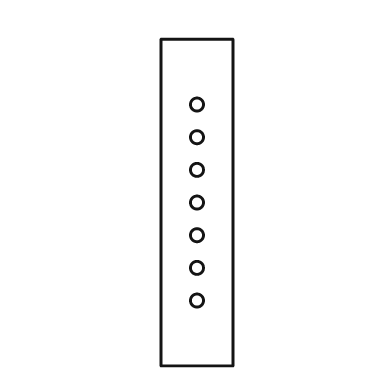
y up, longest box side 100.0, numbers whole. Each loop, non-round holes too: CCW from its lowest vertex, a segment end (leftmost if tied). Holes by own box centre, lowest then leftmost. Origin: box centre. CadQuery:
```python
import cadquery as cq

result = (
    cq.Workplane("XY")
    .moveTo(-11.0, -50.0)
    .lineTo(11.0, -50.0)
    .lineTo(11.0, 50.0)
    .lineTo(-11.0, 50.0)
    .close()
    .moveTo(0.0, -30.0)
    .circle(2.0)
    .moveTo(0.0, -20.0)
    .circle(2.0)
    .moveTo(0.0, -10.0)
    .circle(2.0)
    .moveTo(0.0, 0.0)
    .circle(2.0)
    .moveTo(0.0, 10.0)
    .circle(2.0)
    .moveTo(0.0, 20.0)
    .circle(2.0)
    .moveTo(0.0, 30.0)
    .circle(2.0)
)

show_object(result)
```